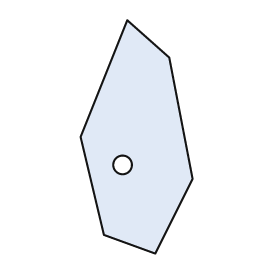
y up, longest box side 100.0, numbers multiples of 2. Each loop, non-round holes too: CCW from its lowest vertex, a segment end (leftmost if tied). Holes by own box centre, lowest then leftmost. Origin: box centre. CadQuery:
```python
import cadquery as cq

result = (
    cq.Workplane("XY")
    .moveTo(8.0, -50.0)
    .lineTo(24.0, -18.0)
    .lineTo(14.0, 34.0)
    .lineTo(-4.0, 50.0)
    .lineTo(-24.0, 0.0)
    .lineTo(-14.0, -42.0)
    .close()
    .moveTo(-6.0, -12.0)
    .circle(4.0)
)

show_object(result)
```